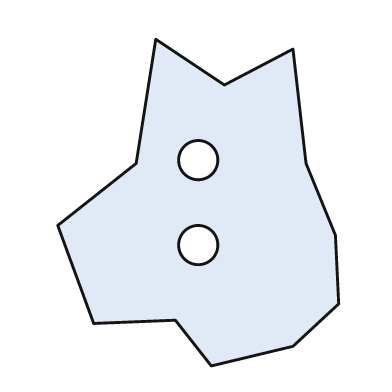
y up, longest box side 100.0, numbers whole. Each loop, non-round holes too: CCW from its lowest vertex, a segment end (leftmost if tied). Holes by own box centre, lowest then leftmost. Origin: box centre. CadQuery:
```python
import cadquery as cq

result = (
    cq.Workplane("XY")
    .moveTo(4.0, -50.0)
    .lineTo(29.0, -44.0)
    .lineTo(43.0, -31.0)
    .lineTo(42.0, -10.0)
    .lineTo(33.0, 12.0)
    .lineTo(29.0, 47.0)
    .lineTo(8.0, 36.0)
    .lineTo(-13.0, 50.0)
    .lineTo(-19.0, 12.0)
    .lineTo(-43.0, -7.0)
    .lineTo(-32.0, -37.0)
    .lineTo(-7.0, -36.0)
    .close()
    .moveTo(0.0, -13.0)
    .circle(6.0)
    .moveTo(0.0, 13.0)
    .circle(6.0)
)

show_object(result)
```